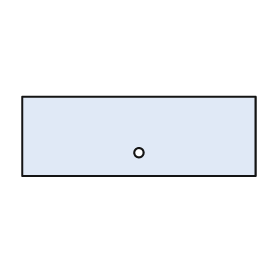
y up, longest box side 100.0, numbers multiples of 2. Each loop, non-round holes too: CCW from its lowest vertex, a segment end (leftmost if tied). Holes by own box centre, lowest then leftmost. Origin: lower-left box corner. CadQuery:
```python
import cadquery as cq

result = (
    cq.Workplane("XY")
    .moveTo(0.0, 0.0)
    .lineTo(100.0, 0.0)
    .lineTo(100.0, 34.0)
    .lineTo(0.0, 34.0)
    .close()
    .moveTo(50.0, 10.0)
    .circle(2.0)
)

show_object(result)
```